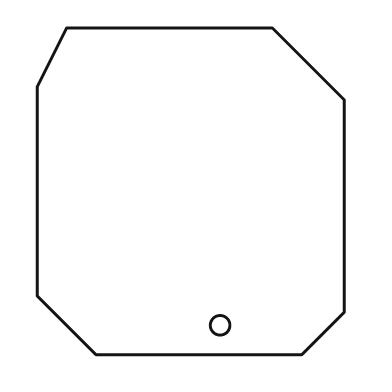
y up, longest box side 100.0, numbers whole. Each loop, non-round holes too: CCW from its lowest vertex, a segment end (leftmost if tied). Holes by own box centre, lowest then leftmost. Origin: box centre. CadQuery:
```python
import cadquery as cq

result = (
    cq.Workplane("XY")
    .moveTo(-29.0, -50.0)
    .lineTo(34.0, -50.0)
    .lineTo(47.0, -37.0)
    .lineTo(47.0, 28.0)
    .lineTo(25.0, 50.0)
    .lineTo(-38.0, 50.0)
    .lineTo(-47.0, 32.0)
    .lineTo(-47.0, -32.0)
    .close()
    .moveTo(9.0, -41.0)
    .circle(3.0)
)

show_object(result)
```